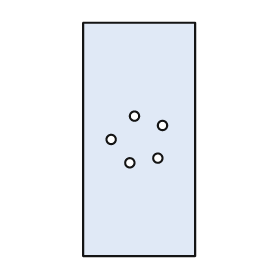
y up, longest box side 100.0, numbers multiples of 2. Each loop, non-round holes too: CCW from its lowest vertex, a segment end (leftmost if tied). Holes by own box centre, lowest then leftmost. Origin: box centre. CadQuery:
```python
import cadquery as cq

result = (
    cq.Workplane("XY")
    .moveTo(-24.0, -50.0)
    .lineTo(24.0, -50.0)
    .lineTo(24.0, 50.0)
    .lineTo(-24.0, 50.0)
    .close()
    .moveTo(-4.0, -10.0)
    .circle(2.0)
    .moveTo(8.0, -8.0)
    .circle(2.0)
    .moveTo(-12.0, 0.0)
    .circle(2.0)
    .moveTo(10.0, 6.0)
    .circle(2.0)
    .moveTo(-2.0, 10.0)
    .circle(2.0)
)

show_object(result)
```